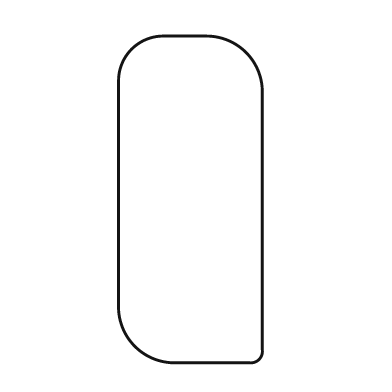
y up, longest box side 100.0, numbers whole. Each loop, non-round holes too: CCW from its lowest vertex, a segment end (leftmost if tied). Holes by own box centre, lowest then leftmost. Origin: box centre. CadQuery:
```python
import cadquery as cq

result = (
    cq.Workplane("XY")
    .moveTo(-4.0, -50.0)
    .lineTo(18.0, -50.0)
    .threePointArc((21.0, -49.0), (22.0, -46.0))
    .lineTo(22.0, 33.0)
    .threePointArc((17.0, 45.0), (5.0, 50.0))
    .lineTo(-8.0, 50.0)
    .threePointArc((-18.0, 46.0), (-22.0, 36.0))
    .lineTo(-22.0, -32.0)
    .threePointArc((-17.0, -45.0), (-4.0, -50.0))
    .close()
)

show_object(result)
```